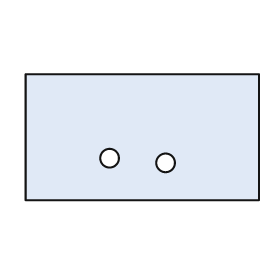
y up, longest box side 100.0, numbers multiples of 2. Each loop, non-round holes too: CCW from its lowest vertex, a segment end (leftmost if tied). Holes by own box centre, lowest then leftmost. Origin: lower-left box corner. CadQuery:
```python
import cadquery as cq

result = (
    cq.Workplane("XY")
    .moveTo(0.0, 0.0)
    .lineTo(100.0, 0.0)
    .lineTo(100.0, 54.0)
    .lineTo(0.0, 54.0)
    .close()
    .moveTo(60.0, 16.0)
    .circle(4.0)
    .moveTo(36.0, 18.0)
    .circle(4.0)
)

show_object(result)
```